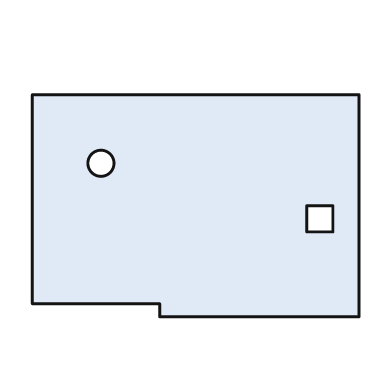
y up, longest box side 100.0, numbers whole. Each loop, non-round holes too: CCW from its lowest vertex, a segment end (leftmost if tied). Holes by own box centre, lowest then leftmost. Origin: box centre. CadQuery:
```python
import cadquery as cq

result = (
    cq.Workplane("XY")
    .moveTo(-11.0, -34.0)
    .lineTo(50.0, -34.0)
    .lineTo(50.0, 34.0)
    .lineTo(-50.0, 34.0)
    .lineTo(-50.0, -30.0)
    .lineTo(-11.0, -30.0)
    .close()
    .moveTo(34.0, -8.0)
    .lineTo(42.0, -8.0)
    .lineTo(42.0, 0.0)
    .lineTo(34.0, 0.0)
    .close()
    .moveTo(-29.0, 13.0)
    .circle(4.0)
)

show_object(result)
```